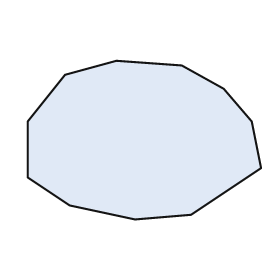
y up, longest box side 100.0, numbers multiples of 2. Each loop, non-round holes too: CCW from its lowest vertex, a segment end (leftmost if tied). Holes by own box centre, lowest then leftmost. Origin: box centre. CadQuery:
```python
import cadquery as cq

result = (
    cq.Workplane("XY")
    .moveTo(-4.0, -34.0)
    .lineTo(20.0, -32.0)
    .lineTo(50.0, -12.0)
    .lineTo(46.0, 8.0)
    .lineTo(34.0, 22.0)
    .lineTo(16.0, 32.0)
    .lineTo(-12.0, 34.0)
    .lineTo(-34.0, 28.0)
    .lineTo(-50.0, 8.0)
    .lineTo(-50.0, -16.0)
    .lineTo(-32.0, -28.0)
    .close()
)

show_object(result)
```